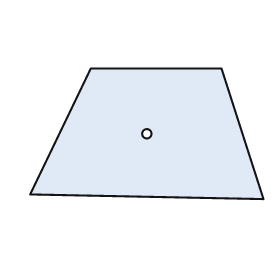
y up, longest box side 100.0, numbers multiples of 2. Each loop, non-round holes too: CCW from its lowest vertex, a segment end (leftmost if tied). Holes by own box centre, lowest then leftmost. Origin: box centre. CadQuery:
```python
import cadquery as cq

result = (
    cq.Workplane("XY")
    .moveTo(50.0, -28.0)
    .lineTo(32.0, 28.0)
    .lineTo(-24.0, 28.0)
    .lineTo(-50.0, -26.0)
    .close()
    .moveTo(0.0, 0.0)
    .circle(2.0)
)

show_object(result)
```